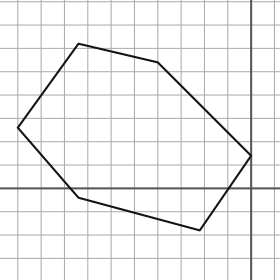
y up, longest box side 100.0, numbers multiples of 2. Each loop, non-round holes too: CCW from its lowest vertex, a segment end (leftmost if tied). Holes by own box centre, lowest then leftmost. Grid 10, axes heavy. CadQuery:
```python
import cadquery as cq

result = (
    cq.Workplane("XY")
    .moveTo(-22.0, -18.0)
    .lineTo(0.0, 14.0)
    .lineTo(-40.0, 54.0)
    .lineTo(-74.0, 62.0)
    .lineTo(-100.0, 26.0)
    .lineTo(-74.0, -4.0)
    .close()
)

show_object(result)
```